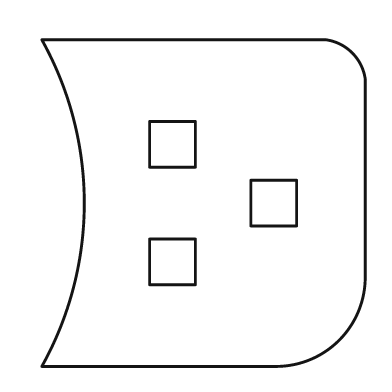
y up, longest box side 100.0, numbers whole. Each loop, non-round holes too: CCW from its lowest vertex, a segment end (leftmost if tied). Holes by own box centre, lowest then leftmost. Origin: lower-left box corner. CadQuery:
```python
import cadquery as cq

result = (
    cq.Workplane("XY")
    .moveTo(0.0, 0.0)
    .lineTo(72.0, 0.0)
    .threePointArc((91.0, 8.0), (99.0, 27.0))
    .lineTo(99.0, 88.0)
    .threePointArc((95.0, 96.0), (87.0, 100.0))
    .lineTo(0.0, 100.0)
    .threePointArc((13.0, 50.0), (0.0, 0.0))
    .close()
    .moveTo(33.0, 25.0)
    .lineTo(47.0, 25.0)
    .lineTo(47.0, 39.0)
    .lineTo(33.0, 39.0)
    .close()
    .moveTo(64.0, 43.0)
    .lineTo(78.0, 43.0)
    .lineTo(78.0, 57.0)
    .lineTo(64.0, 57.0)
    .close()
    .moveTo(33.0, 61.0)
    .lineTo(47.0, 61.0)
    .lineTo(47.0, 75.0)
    .lineTo(33.0, 75.0)
    .close()
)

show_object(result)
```